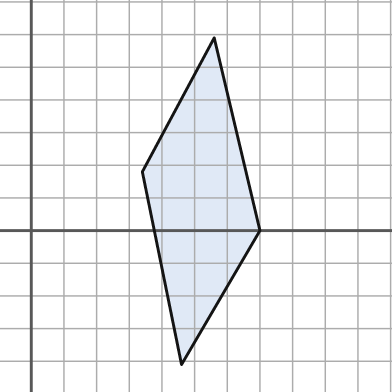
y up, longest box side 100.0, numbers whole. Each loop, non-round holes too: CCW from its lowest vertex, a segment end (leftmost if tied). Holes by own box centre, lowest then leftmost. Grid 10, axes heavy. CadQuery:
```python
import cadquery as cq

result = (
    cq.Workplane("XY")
    .moveTo(46.0, -41.0)
    .lineTo(70.0, 0.0)
    .lineTo(56.0, 59.0)
    .lineTo(34.0, 18.0)
    .close()
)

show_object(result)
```